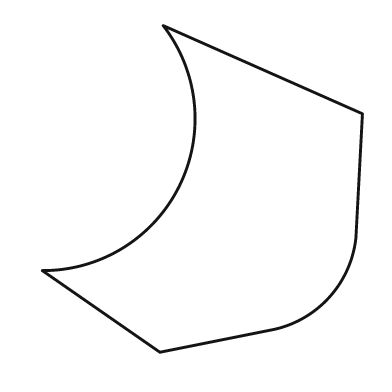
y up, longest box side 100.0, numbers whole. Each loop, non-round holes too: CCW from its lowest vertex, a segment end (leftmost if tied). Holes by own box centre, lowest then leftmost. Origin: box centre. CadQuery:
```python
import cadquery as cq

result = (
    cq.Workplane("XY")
    .moveTo(-13.0, -50.0)
    .lineTo(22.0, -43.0)
    .threePointArc((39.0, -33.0), (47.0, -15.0))
    .lineTo(49.0, 23.0)
    .lineTo(-12.0, 50.0)
    .threePointArc((-7.0, 1.0), (-49.0, -25.0))
    .close()
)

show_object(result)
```